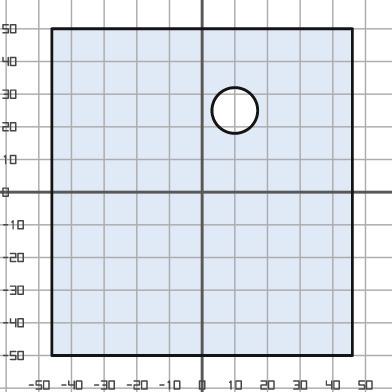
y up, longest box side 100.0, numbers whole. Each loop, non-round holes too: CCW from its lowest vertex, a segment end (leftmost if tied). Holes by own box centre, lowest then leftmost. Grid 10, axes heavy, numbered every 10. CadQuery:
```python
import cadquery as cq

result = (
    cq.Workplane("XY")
    .moveTo(-46.0, -50.0)
    .lineTo(46.0, -50.0)
    .lineTo(46.0, 50.0)
    .lineTo(-46.0, 50.0)
    .close()
    .moveTo(10.0, 25.0)
    .circle(7.0)
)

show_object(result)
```